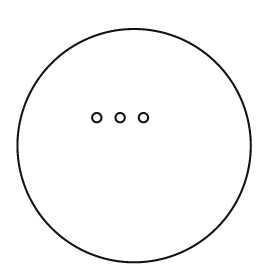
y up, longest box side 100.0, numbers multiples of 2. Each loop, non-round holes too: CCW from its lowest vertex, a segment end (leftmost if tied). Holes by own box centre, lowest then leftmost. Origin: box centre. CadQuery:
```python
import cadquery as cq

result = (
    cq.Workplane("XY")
    .moveTo(0.0, 0.0)
    .circle(50.0)
    .moveTo(-16.0, 12.0)
    .circle(2.0)
    .moveTo(-6.0, 12.0)
    .circle(2.0)
    .moveTo(4.0, 12.0)
    .circle(2.0)
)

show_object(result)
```